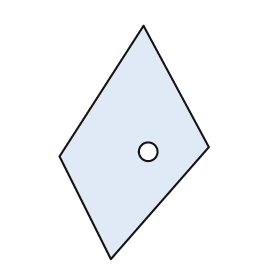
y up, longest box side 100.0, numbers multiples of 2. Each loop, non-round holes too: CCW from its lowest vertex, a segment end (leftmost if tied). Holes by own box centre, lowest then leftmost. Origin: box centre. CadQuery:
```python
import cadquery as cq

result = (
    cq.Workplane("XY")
    .moveTo(-10.0, -50.0)
    .lineTo(32.0, -2.0)
    .lineTo(4.0, 50.0)
    .lineTo(-32.0, -6.0)
    .close()
    .moveTo(6.0, -4.0)
    .circle(4.0)
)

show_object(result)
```